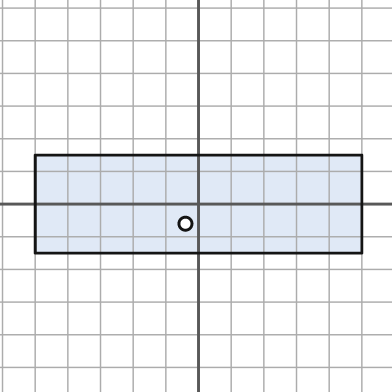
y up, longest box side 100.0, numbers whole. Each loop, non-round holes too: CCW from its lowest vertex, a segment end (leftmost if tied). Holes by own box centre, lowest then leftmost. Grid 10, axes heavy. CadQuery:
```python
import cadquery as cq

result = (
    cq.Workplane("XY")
    .moveTo(-50.0, -15.0)
    .lineTo(50.0, -15.0)
    .lineTo(50.0, 15.0)
    .lineTo(-50.0, 15.0)
    .close()
    .moveTo(-4.0, -6.0)
    .circle(2.0)
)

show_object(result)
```